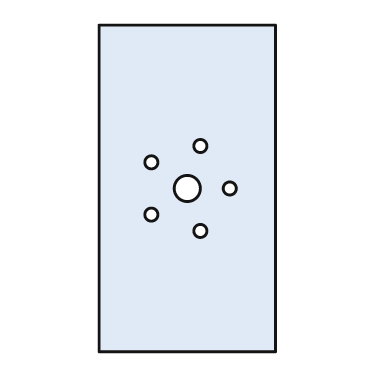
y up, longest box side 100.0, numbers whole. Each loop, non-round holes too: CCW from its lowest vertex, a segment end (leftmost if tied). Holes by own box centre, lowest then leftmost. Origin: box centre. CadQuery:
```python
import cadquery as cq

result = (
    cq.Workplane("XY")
    .moveTo(-27.0, -50.0)
    .lineTo(27.0, -50.0)
    .lineTo(27.0, 50.0)
    .lineTo(-27.0, 50.0)
    .close()
    .moveTo(4.0, -13.0)
    .circle(2.0)
    .moveTo(-11.0, -8.0)
    .circle(2.0)
    .moveTo(0.0, 0.0)
    .circle(4.0)
    .moveTo(13.0, 0.0)
    .circle(2.0)
    .moveTo(-11.0, 8.0)
    .circle(2.0)
    .moveTo(4.0, 13.0)
    .circle(2.0)
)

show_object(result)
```